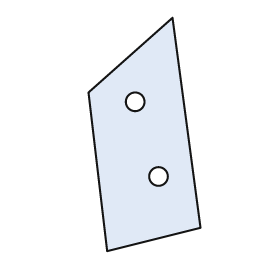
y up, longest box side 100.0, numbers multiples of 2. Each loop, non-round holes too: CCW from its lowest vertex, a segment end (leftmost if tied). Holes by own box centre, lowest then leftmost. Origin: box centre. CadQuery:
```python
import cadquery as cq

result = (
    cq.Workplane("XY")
    .moveTo(-16.0, -50.0)
    .lineTo(24.0, -40.0)
    .lineTo(12.0, 50.0)
    .lineTo(-24.0, 18.0)
    .close()
    .moveTo(6.0, -18.0)
    .circle(4.0)
    .moveTo(-4.0, 14.0)
    .circle(4.0)
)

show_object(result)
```